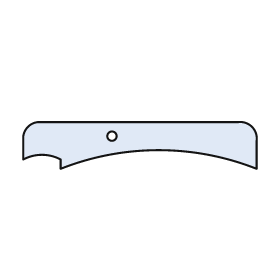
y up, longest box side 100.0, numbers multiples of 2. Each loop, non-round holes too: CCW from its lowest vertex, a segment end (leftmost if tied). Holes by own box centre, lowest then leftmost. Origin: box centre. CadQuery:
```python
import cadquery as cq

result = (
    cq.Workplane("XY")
    .moveTo(-34.0, -10.0)
    .threePointArc((8.0, -2.0), (50.0, -10.0))
    .lineTo(50.0, 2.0)
    .threePointArc((48.0, 8.0), (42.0, 10.0))
    .lineTo(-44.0, 10.0)
    .threePointArc((-48.0, 8.0), (-50.0, 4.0))
    .lineTo(-50.0, -6.0)
    .threePointArc((-42.0, -4.0), (-34.0, -6.0))
    .close()
    .moveTo(-12.0, 4.0)
    .circle(2.0)
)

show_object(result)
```